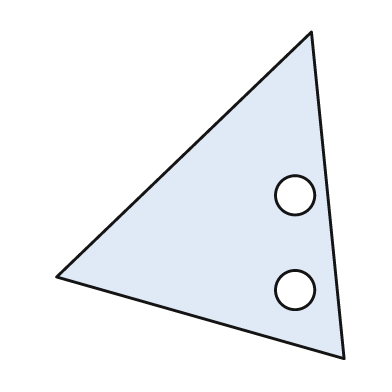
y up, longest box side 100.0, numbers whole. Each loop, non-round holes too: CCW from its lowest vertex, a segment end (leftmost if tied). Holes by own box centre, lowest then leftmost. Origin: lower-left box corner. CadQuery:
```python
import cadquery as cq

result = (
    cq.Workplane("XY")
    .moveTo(88.0, 0.0)
    .lineTo(78.0, 100.0)
    .lineTo(0.0, 25.0)
    .close()
    .moveTo(73.0, 21.0)
    .circle(6.0)
    .moveTo(73.0, 50.0)
    .circle(6.0)
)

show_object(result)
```